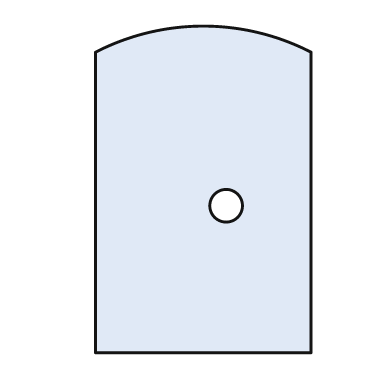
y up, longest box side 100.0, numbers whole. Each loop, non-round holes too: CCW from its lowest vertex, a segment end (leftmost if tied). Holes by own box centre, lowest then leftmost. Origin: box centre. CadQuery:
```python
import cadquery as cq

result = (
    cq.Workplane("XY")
    .moveTo(-33.0, -50.0)
    .lineTo(33.0, -50.0)
    .lineTo(33.0, 42.0)
    .threePointArc((0.0, 50.0), (-33.0, 42.0))
    .close()
    .moveTo(7.0, -5.0)
    .circle(5.0)
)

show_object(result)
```